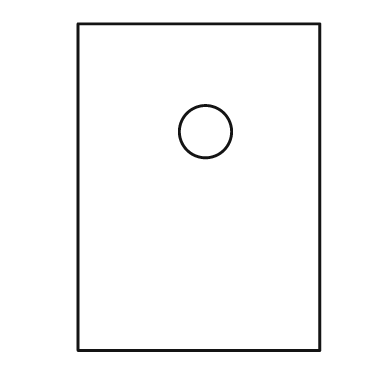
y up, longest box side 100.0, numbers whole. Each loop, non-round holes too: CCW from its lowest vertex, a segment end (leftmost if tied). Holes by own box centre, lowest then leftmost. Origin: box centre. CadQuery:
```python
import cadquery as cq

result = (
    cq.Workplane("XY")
    .moveTo(-37.0, -50.0)
    .lineTo(37.0, -50.0)
    .lineTo(37.0, 50.0)
    .lineTo(-37.0, 50.0)
    .close()
    .moveTo(2.0, 17.0)
    .circle(8.0)
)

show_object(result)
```